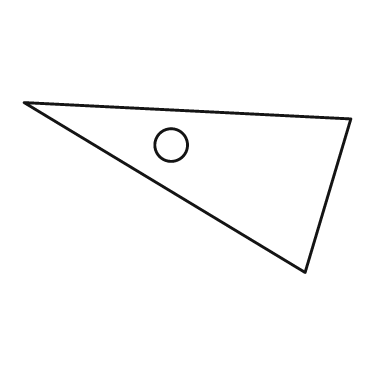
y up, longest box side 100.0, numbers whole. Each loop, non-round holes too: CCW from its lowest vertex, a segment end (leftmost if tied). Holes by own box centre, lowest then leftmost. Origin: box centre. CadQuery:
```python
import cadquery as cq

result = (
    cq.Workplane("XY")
    .moveTo(36.0, -26.0)
    .lineTo(50.0, 21.0)
    .lineTo(-50.0, 26.0)
    .close()
    .moveTo(-5.0, 13.0)
    .circle(5.0)
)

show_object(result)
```